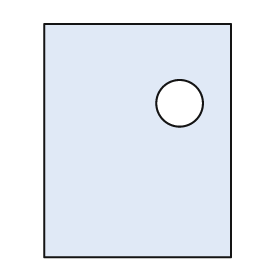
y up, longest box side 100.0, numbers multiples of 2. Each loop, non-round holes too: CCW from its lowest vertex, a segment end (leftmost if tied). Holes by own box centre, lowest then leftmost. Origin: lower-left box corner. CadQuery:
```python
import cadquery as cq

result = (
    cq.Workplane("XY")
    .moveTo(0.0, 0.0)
    .lineTo(80.0, 0.0)
    .lineTo(80.0, 100.0)
    .lineTo(0.0, 100.0)
    .close()
    .moveTo(58.0, 66.0)
    .circle(10.0)
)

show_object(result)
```